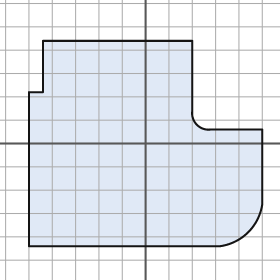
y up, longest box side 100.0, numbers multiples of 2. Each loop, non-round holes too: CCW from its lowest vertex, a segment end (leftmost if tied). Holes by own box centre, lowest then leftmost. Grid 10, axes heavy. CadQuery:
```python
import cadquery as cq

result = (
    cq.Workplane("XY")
    .moveTo(-50.0, -44.0)
    .lineTo(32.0, -44.0)
    .threePointArc((44.0, -38.0), (50.0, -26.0))
    .lineTo(50.0, 6.0)
    .lineTo(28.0, 6.0)
    .threePointArc((22.0, 8.0), (20.0, 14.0))
    .lineTo(20.0, 44.0)
    .lineTo(-44.0, 44.0)
    .lineTo(-44.0, 22.0)
    .lineTo(-50.0, 22.0)
    .close()
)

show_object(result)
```